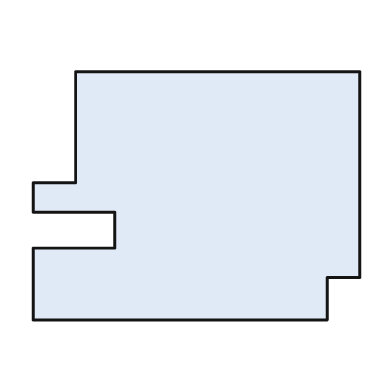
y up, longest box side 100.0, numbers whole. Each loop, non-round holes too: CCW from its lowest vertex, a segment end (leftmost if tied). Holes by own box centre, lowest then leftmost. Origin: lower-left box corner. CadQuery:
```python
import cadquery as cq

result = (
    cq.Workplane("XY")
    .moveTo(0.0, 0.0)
    .lineTo(90.0, 0.0)
    .lineTo(90.0, 13.0)
    .lineTo(100.0, 13.0)
    .lineTo(100.0, 76.0)
    .lineTo(13.0, 76.0)
    .lineTo(13.0, 42.0)
    .lineTo(0.0, 42.0)
    .lineTo(0.0, 33.0)
    .lineTo(25.0, 33.0)
    .lineTo(25.0, 22.0)
    .lineTo(0.0, 22.0)
    .close()
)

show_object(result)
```